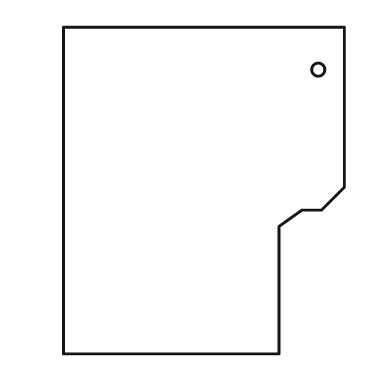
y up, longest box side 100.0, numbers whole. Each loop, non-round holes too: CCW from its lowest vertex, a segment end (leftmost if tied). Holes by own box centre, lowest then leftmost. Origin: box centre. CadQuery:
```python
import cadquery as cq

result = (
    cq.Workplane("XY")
    .moveTo(-43.0, -50.0)
    .lineTo(23.0, -50.0)
    .lineTo(23.0, -11.0)
    .lineTo(30.0, -6.0)
    .lineTo(36.0, -6.0)
    .lineTo(43.0, 1.0)
    .lineTo(43.0, 50.0)
    .lineTo(-43.0, 50.0)
    .close()
    .moveTo(35.0, 37.0)
    .circle(2.0)
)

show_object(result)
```